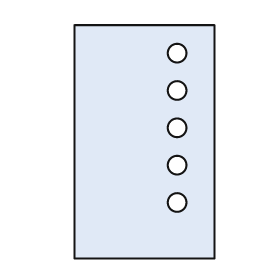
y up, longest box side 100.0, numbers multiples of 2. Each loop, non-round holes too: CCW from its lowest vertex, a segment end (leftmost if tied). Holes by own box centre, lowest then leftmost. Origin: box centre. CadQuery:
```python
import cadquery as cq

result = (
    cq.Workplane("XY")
    .moveTo(-30.0, -50.0)
    .lineTo(30.0, -50.0)
    .lineTo(30.0, 50.0)
    .lineTo(-30.0, 50.0)
    .close()
    .moveTo(14.0, -26.0)
    .circle(4.0)
    .moveTo(14.0, -10.0)
    .circle(4.0)
    .moveTo(14.0, 6.0)
    .circle(4.0)
    .moveTo(14.0, 22.0)
    .circle(4.0)
    .moveTo(14.0, 38.0)
    .circle(4.0)
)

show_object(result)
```